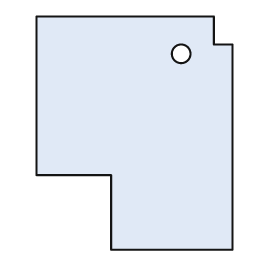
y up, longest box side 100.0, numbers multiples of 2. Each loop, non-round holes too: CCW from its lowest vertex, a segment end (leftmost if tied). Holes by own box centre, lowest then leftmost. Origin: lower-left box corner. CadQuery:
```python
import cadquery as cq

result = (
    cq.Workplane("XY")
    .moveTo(32.0, 0.0)
    .lineTo(84.0, 0.0)
    .lineTo(84.0, 88.0)
    .lineTo(76.0, 88.0)
    .lineTo(76.0, 100.0)
    .lineTo(0.0, 100.0)
    .lineTo(0.0, 32.0)
    .lineTo(32.0, 32.0)
    .close()
    .moveTo(62.0, 84.0)
    .circle(4.0)
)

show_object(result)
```